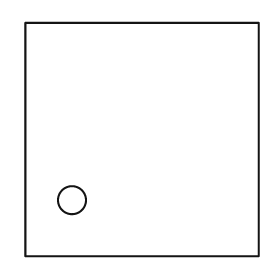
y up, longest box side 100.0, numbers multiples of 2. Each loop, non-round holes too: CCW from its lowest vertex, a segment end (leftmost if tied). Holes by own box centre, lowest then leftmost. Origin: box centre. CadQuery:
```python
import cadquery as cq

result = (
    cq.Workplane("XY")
    .moveTo(-50.0, -50.0)
    .lineTo(50.0, -50.0)
    .lineTo(50.0, 50.0)
    .lineTo(-50.0, 50.0)
    .close()
    .moveTo(-30.0, -26.0)
    .circle(6.0)
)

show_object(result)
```